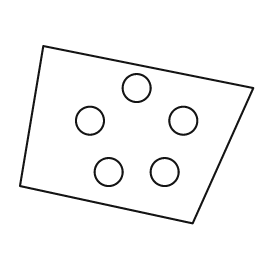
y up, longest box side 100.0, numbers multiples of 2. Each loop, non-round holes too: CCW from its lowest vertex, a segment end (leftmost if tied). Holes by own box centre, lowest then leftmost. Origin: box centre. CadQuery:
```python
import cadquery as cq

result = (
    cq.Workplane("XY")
    .moveTo(24.0, -38.0)
    .lineTo(50.0, 20.0)
    .lineTo(-40.0, 38.0)
    .lineTo(-50.0, -22.0)
    .close()
    .moveTo(-12.0, -16.0)
    .circle(6.0)
    .moveTo(12.0, -16.0)
    .circle(6.0)
    .moveTo(-20.0, 6.0)
    .circle(6.0)
    .moveTo(20.0, 6.0)
    .circle(6.0)
    .moveTo(0.0, 20.0)
    .circle(6.0)
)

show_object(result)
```